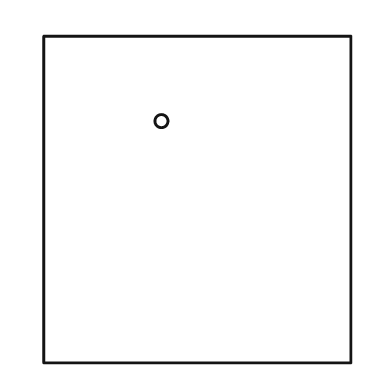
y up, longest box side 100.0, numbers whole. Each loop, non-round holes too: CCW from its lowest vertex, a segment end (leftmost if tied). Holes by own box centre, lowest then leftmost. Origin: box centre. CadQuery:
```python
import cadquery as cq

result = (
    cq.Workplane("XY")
    .moveTo(-47.0, -50.0)
    .lineTo(47.0, -50.0)
    .lineTo(47.0, 50.0)
    .lineTo(-47.0, 50.0)
    .close()
    .moveTo(-11.0, 24.0)
    .circle(2.0)
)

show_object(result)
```